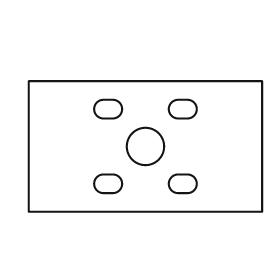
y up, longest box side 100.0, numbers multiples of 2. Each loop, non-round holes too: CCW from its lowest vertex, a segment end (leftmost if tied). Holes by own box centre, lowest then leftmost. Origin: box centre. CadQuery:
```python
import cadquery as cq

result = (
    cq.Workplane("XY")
    .moveTo(-50.0, -28.0)
    .lineTo(50.0, -28.0)
    .lineTo(50.0, 28.0)
    .lineTo(-50.0, 28.0)
    .close()
    .moveTo(-18.0, -20.0)
    .lineTo(-14.0, -20.0)
    .threePointArc((-10.0, -16.0), (-14.0, -12.0))
    .lineTo(-18.0, -12.0)
    .threePointArc((-22.0, -16.0), (-18.0, -20.0))
    .close()
    .moveTo(14.0, -20.0)
    .lineTo(18.0, -20.0)
    .threePointArc((22.0, -16.0), (18.0, -12.0))
    .lineTo(14.0, -12.0)
    .threePointArc((10.0, -16.0), (14.0, -20.0))
    .close()
    .moveTo(0.0, 0.0)
    .circle(8.0)
    .moveTo(-18.0, 12.0)
    .lineTo(-14.0, 12.0)
    .threePointArc((-10.0, 16.0), (-14.0, 20.0))
    .lineTo(-18.0, 20.0)
    .threePointArc((-22.0, 16.0), (-18.0, 12.0))
    .close()
    .moveTo(14.0, 12.0)
    .lineTo(18.0, 12.0)
    .threePointArc((22.0, 16.0), (18.0, 20.0))
    .lineTo(14.0, 20.0)
    .threePointArc((10.0, 16.0), (14.0, 12.0))
    .close()
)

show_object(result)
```